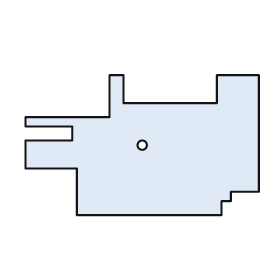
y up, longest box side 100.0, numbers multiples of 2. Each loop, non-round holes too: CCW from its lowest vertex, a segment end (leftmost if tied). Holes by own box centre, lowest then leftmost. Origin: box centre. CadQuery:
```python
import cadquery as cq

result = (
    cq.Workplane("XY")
    .moveTo(-28.0, -30.0)
    .lineTo(34.0, -30.0)
    .lineTo(34.0, -24.0)
    .lineTo(38.0, -24.0)
    .lineTo(38.0, -20.0)
    .lineTo(50.0, -20.0)
    .lineTo(50.0, 30.0)
    .lineTo(32.0, 30.0)
    .lineTo(32.0, 18.0)
    .lineTo(-8.0, 18.0)
    .lineTo(-8.0, 30.0)
    .lineTo(-14.0, 30.0)
    .lineTo(-14.0, 12.0)
    .lineTo(-50.0, 12.0)
    .lineTo(-50.0, 8.0)
    .lineTo(-30.0, 8.0)
    .lineTo(-30.0, 2.0)
    .lineTo(-50.0, 2.0)
    .lineTo(-50.0, -10.0)
    .lineTo(-28.0, -10.0)
    .close()
    .moveTo(0.0, 0.0)
    .circle(2.0)
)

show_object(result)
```